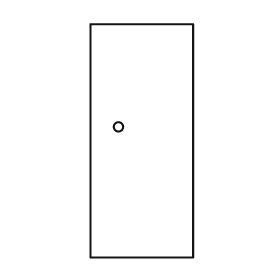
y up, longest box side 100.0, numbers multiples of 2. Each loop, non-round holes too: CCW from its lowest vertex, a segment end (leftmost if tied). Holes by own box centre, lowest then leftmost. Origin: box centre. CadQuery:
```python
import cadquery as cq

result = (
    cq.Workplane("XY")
    .moveTo(-22.0, -50.0)
    .lineTo(22.0, -50.0)
    .lineTo(22.0, 50.0)
    .lineTo(-22.0, 50.0)
    .close()
    .moveTo(-10.0, 6.0)
    .circle(2.0)
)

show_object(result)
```